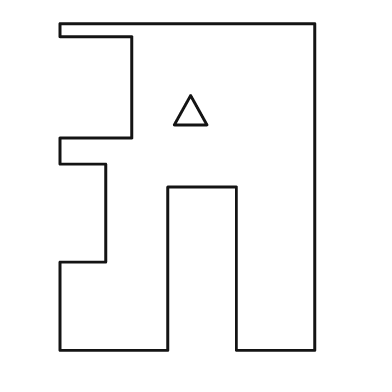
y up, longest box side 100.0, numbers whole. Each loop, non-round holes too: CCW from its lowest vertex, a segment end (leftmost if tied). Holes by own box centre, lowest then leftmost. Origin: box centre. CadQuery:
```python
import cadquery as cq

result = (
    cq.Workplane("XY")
    .moveTo(-39.0, -50.0)
    .lineTo(-6.0, -50.0)
    .lineTo(-6.0, 0.0)
    .lineTo(15.0, 0.0)
    .lineTo(15.0, -50.0)
    .lineTo(39.0, -50.0)
    .lineTo(39.0, 50.0)
    .lineTo(-39.0, 50.0)
    .lineTo(-39.0, 46.0)
    .lineTo(-17.0, 46.0)
    .lineTo(-17.0, 15.0)
    .lineTo(-39.0, 15.0)
    .lineTo(-39.0, 7.0)
    .lineTo(-25.0, 7.0)
    .lineTo(-25.0, -23.0)
    .lineTo(-39.0, -23.0)
    .close()
    .moveTo(-4.0, 19.0)
    .lineTo(6.0, 19.0)
    .lineTo(1.0, 28.0)
    .close()
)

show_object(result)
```